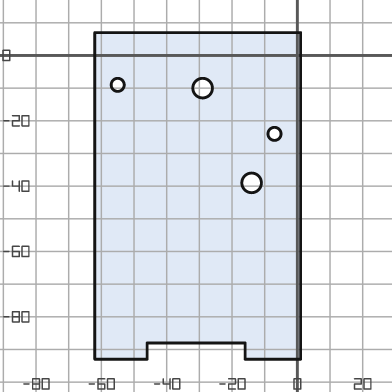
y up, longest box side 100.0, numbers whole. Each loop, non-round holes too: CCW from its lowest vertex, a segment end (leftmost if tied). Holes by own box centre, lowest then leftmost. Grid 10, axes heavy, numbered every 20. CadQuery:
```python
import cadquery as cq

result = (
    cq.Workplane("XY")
    .moveTo(-62.0, -93.0)
    .lineTo(-46.0, -93.0)
    .lineTo(-46.0, -88.0)
    .lineTo(-16.0, -88.0)
    .lineTo(-16.0, -93.0)
    .lineTo(1.0, -93.0)
    .lineTo(1.0, 7.0)
    .lineTo(-62.0, 7.0)
    .close()
    .moveTo(-14.0, -39.0)
    .circle(3.0)
    .moveTo(-7.0, -24.0)
    .circle(2.0)
    .moveTo(-29.0, -10.0)
    .circle(3.0)
    .moveTo(-55.0, -9.0)
    .circle(2.0)
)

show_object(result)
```